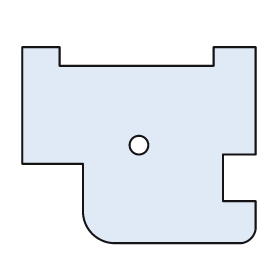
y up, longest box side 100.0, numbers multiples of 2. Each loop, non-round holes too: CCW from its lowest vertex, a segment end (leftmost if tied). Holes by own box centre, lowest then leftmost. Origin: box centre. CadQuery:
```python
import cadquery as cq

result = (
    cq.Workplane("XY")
    .moveTo(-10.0, -42.0)
    .lineTo(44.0, -42.0)
    .threePointArc((48.0, -40.0), (50.0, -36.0))
    .lineTo(50.0, -24.0)
    .lineTo(36.0, -24.0)
    .lineTo(36.0, -4.0)
    .lineTo(50.0, -4.0)
    .lineTo(50.0, 42.0)
    .lineTo(32.0, 42.0)
    .lineTo(32.0, 34.0)
    .lineTo(-34.0, 34.0)
    .lineTo(-34.0, 42.0)
    .lineTo(-50.0, 42.0)
    .lineTo(-50.0, -8.0)
    .lineTo(-24.0, -8.0)
    .lineTo(-24.0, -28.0)
    .threePointArc((-20.0, -38.0), (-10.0, -42.0))
    .close()
    .moveTo(0.0, 0.0)
    .circle(4.0)
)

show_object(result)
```